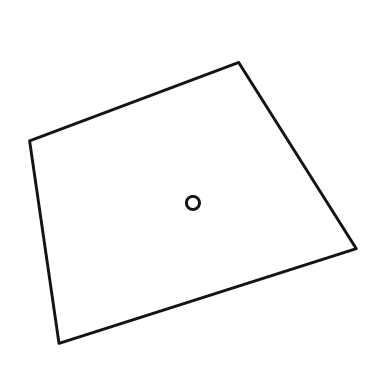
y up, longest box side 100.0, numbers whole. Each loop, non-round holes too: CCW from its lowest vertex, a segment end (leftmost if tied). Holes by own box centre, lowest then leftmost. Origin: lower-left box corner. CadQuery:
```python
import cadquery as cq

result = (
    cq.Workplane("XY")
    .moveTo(9.0, 0.0)
    .lineTo(100.0, 29.0)
    .lineTo(64.0, 86.0)
    .lineTo(0.0, 62.0)
    .close()
    .moveTo(50.0, 43.0)
    .circle(2.0)
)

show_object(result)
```